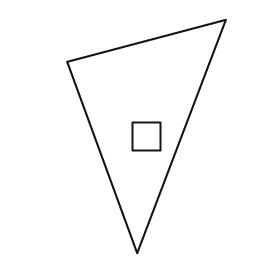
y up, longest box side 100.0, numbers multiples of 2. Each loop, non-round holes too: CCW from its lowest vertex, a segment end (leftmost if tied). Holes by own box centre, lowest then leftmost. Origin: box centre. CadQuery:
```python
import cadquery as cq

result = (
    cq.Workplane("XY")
    .moveTo(-4.0, -50.0)
    .lineTo(34.0, 50.0)
    .lineTo(-34.0, 32.0)
    .close()
    .moveTo(-6.0, -6.0)
    .lineTo(6.0, -6.0)
    .lineTo(6.0, 6.0)
    .lineTo(-6.0, 6.0)
    .close()
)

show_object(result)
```